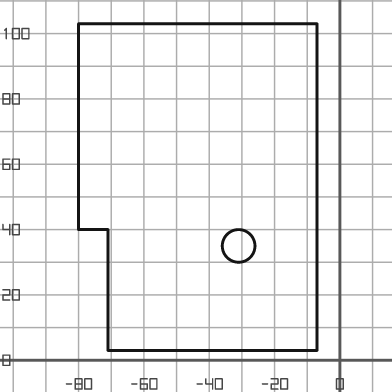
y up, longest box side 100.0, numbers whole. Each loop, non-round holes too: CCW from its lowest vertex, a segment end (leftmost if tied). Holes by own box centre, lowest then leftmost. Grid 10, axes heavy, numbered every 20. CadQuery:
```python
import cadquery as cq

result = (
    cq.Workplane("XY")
    .moveTo(-71.0, 3.0)
    .lineTo(-7.0, 3.0)
    .lineTo(-7.0, 103.0)
    .lineTo(-80.0, 103.0)
    .lineTo(-80.0, 40.0)
    .lineTo(-71.0, 40.0)
    .close()
    .moveTo(-31.0, 35.0)
    .circle(5.0)
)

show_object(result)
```